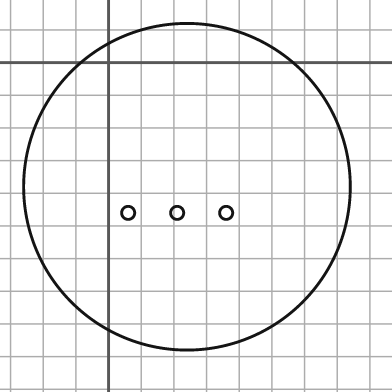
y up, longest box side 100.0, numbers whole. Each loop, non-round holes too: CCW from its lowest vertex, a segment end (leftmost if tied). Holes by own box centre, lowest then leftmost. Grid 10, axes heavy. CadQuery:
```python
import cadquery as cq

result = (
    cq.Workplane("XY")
    .moveTo(24.0, -38.0)
    .circle(50.0)
    .moveTo(6.0, -46.0)
    .circle(2.0)
    .moveTo(21.0, -46.0)
    .circle(2.0)
    .moveTo(36.0, -46.0)
    .circle(2.0)
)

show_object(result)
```